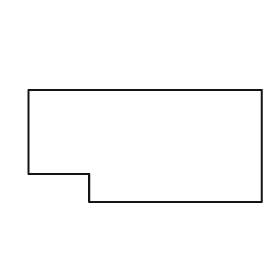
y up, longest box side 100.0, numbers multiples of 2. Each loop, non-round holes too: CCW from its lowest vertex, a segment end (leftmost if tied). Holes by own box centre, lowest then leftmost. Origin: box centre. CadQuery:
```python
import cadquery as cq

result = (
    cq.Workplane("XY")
    .moveTo(-24.0, -24.0)
    .lineTo(50.0, -24.0)
    .lineTo(50.0, 24.0)
    .lineTo(-50.0, 24.0)
    .lineTo(-50.0, -12.0)
    .lineTo(-24.0, -12.0)
    .close()
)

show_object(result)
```